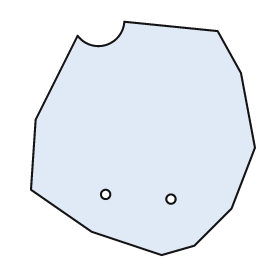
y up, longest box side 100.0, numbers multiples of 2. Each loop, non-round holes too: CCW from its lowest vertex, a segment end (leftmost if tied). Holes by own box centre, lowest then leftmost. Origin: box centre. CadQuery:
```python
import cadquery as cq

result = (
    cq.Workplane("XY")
    .moveTo(8.0, -50.0)
    .lineTo(22.0, -46.0)
    .lineTo(38.0, -30.0)
    .lineTo(48.0, -4.0)
    .lineTo(42.0, 28.0)
    .lineTo(32.0, 46.0)
    .lineTo(-8.0, 50.0)
    .threePointArc((-16.0, 40.0), (-28.0, 44.0))
    .lineTo(-46.0, 8.0)
    .lineTo(-48.0, -22.0)
    .lineTo(-22.0, -40.0)
    .close()
    .moveTo(12.0, -26.0)
    .circle(2.0)
    .moveTo(-16.0, -24.0)
    .circle(2.0)
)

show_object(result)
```